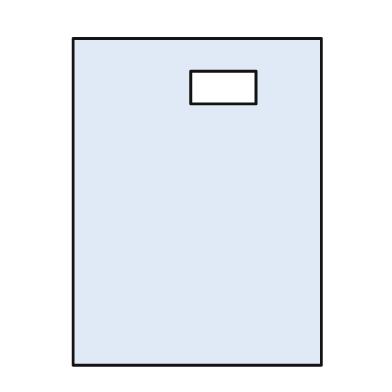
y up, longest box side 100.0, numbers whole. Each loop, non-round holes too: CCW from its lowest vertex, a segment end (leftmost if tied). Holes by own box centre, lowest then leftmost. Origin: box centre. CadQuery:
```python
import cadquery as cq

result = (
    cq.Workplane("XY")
    .moveTo(-38.0, -50.0)
    .lineTo(38.0, -50.0)
    .lineTo(38.0, 50.0)
    .lineTo(-38.0, 50.0)
    .close()
    .moveTo(-2.0, 30.0)
    .lineTo(18.0, 30.0)
    .lineTo(18.0, 40.0)
    .lineTo(-2.0, 40.0)
    .close()
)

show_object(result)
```